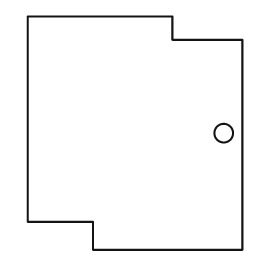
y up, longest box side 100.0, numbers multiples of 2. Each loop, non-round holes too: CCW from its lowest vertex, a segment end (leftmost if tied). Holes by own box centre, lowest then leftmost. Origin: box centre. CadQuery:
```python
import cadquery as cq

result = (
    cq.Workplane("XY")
    .moveTo(-18.0, -50.0)
    .lineTo(46.0, -50.0)
    .lineTo(46.0, 40.0)
    .lineTo(16.0, 40.0)
    .lineTo(16.0, 50.0)
    .lineTo(-46.0, 50.0)
    .lineTo(-46.0, -38.0)
    .lineTo(-18.0, -38.0)
    .close()
    .moveTo(38.0, 0.0)
    .circle(4.0)
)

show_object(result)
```